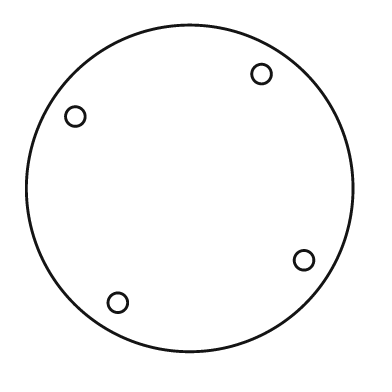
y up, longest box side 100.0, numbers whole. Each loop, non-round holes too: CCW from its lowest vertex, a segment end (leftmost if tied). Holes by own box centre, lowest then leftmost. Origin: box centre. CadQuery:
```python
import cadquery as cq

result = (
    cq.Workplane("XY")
    .moveTo(0.0, 0.0)
    .circle(50.0)
    .moveTo(-22.0, -35.0)
    .circle(3.0)
    .moveTo(35.0, -22.0)
    .circle(3.0)
    .moveTo(-35.0, 22.0)
    .circle(3.0)
    .moveTo(22.0, 35.0)
    .circle(3.0)
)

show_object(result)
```